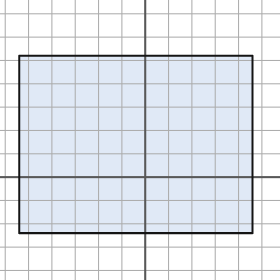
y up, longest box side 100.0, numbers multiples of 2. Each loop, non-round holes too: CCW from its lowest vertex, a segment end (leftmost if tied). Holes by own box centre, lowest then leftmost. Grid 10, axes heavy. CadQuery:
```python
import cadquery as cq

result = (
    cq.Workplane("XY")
    .moveTo(-54.0, -24.0)
    .lineTo(46.0, -24.0)
    .lineTo(46.0, 52.0)
    .lineTo(-54.0, 52.0)
    .close()
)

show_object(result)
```